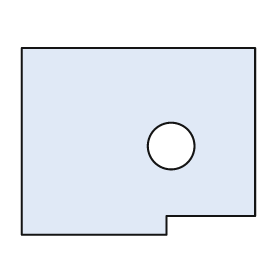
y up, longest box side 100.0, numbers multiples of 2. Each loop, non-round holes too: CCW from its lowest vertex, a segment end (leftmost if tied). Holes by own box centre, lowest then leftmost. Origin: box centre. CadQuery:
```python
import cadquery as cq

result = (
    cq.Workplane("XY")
    .moveTo(-50.0, -40.0)
    .lineTo(12.0, -40.0)
    .lineTo(12.0, -32.0)
    .lineTo(50.0, -32.0)
    .lineTo(50.0, 40.0)
    .lineTo(-50.0, 40.0)
    .close()
    .moveTo(14.0, -2.0)
    .circle(10.0)
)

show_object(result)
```